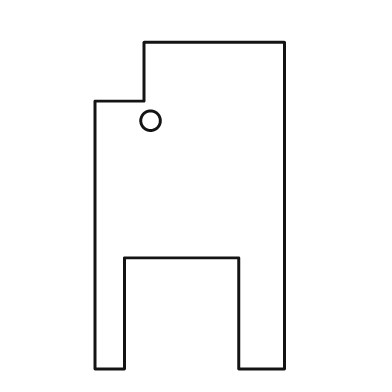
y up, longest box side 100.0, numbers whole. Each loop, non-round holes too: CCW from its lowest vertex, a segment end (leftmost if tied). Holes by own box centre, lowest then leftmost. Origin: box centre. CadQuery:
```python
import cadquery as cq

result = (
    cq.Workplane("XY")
    .moveTo(-29.0, -50.0)
    .lineTo(-20.0, -50.0)
    .lineTo(-20.0, -16.0)
    .lineTo(15.0, -16.0)
    .lineTo(15.0, -50.0)
    .lineTo(29.0, -50.0)
    .lineTo(29.0, 50.0)
    .lineTo(-14.0, 50.0)
    .lineTo(-14.0, 32.0)
    .lineTo(-29.0, 32.0)
    .close()
    .moveTo(-12.0, 26.0)
    .circle(3.0)
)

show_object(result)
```